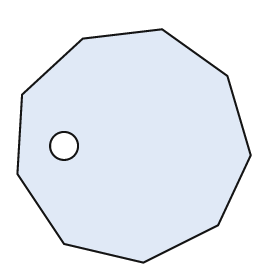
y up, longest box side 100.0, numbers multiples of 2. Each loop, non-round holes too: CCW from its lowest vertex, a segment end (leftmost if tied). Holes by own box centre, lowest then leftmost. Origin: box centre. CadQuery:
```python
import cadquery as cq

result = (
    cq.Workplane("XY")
    .moveTo(4.0, -50.0)
    .lineTo(36.0, -34.0)
    .lineTo(50.0, -4.0)
    .lineTo(40.0, 30.0)
    .lineTo(12.0, 50.0)
    .lineTo(-22.0, 46.0)
    .lineTo(-48.0, 22.0)
    .lineTo(-50.0, -12.0)
    .lineTo(-30.0, -42.0)
    .close()
    .moveTo(-30.0, 0.0)
    .circle(6.0)
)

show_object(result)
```